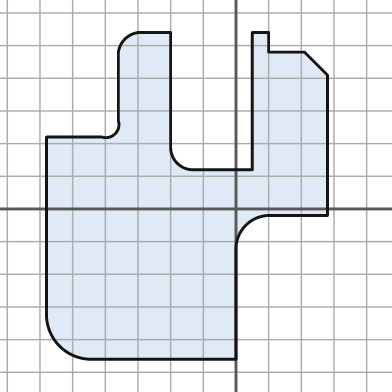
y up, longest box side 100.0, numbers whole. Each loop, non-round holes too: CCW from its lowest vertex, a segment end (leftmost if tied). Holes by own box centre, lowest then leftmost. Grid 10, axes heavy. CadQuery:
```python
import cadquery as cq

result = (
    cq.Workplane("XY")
    .moveTo(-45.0, -46.0)
    .lineTo(0.0, -46.0)
    .lineTo(0.0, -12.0)
    .threePointArc((3.0, -5.0), (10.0, -2.0))
    .lineTo(28.0, -2.0)
    .lineTo(28.0, 41.0)
    .lineTo(21.0, 48.0)
    .lineTo(10.0, 48.0)
    .lineTo(10.0, 54.0)
    .lineTo(5.0, 54.0)
    .lineTo(5.0, 12.0)
    .lineTo(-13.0, 12.0)
    .threePointArc((-18.0, 14.0), (-20.0, 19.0))
    .lineTo(-20.0, 54.0)
    .lineTo(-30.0, 54.0)
    .threePointArc((-34.0, 52.0), (-36.0, 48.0))
    .lineTo(-36.0, 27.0)
    .threePointArc((-37.0, 23.0), (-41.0, 22.0))
    .lineTo(-58.0, 22.0)
    .lineTo(-58.0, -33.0)
    .threePointArc((-54.0, -42.0), (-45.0, -46.0))
    .close()
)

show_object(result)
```